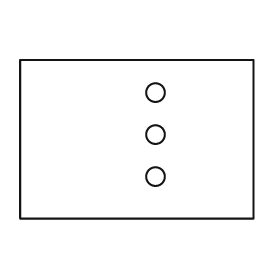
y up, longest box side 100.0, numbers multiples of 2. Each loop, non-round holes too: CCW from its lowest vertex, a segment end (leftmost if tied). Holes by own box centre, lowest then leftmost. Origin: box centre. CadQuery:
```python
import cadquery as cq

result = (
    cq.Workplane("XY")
    .moveTo(-50.0, -34.0)
    .lineTo(50.0, -34.0)
    .lineTo(50.0, 34.0)
    .lineTo(-50.0, 34.0)
    .close()
    .moveTo(8.0, -16.0)
    .circle(4.0)
    .moveTo(8.0, 2.0)
    .circle(4.0)
    .moveTo(8.0, 20.0)
    .circle(4.0)
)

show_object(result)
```